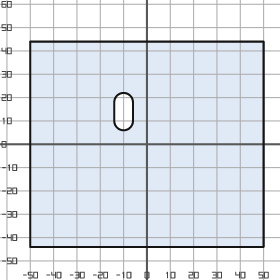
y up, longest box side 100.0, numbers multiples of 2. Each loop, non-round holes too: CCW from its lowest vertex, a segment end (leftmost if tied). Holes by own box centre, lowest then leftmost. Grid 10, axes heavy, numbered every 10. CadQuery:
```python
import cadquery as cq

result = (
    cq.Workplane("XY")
    .moveTo(-50.0, -44.0)
    .lineTo(50.0, -44.0)
    .lineTo(50.0, 44.0)
    .lineTo(-50.0, 44.0)
    .close()
    .moveTo(-14.0, 10.0)
    .threePointArc((-10.0, 6.0), (-6.0, 10.0))
    .lineTo(-6.0, 18.0)
    .threePointArc((-10.0, 22.0), (-14.0, 18.0))
    .close()
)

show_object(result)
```